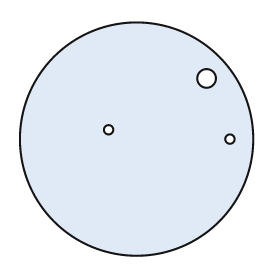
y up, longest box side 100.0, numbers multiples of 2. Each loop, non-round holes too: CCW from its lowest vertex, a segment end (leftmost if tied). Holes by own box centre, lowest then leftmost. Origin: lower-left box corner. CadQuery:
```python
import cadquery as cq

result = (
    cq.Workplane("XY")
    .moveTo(50.0, 50.0)
    .circle(50.0)
    .moveTo(90.0, 50.0)
    .circle(2.0)
    .moveTo(38.0, 54.0)
    .circle(2.0)
    .moveTo(80.0, 76.0)
    .circle(4.0)
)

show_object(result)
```